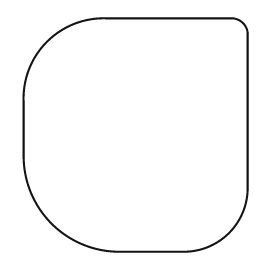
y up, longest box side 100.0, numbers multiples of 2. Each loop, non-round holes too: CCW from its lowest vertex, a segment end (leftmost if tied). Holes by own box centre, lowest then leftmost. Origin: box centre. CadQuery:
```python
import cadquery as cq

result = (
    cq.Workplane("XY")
    .moveTo(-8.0, -50.0)
    .lineTo(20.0, -50.0)
    .threePointArc((40.0, -42.0), (48.0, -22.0))
    .lineTo(48.0, 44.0)
    .threePointArc((46.0, 48.0), (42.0, 50.0))
    .lineTo(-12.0, 50.0)
    .threePointArc((-38.0, 40.0), (-48.0, 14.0))
    .lineTo(-48.0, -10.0)
    .threePointArc((-36.0, -38.0), (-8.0, -50.0))
    .close()
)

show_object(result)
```